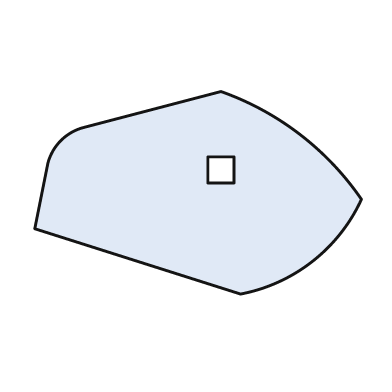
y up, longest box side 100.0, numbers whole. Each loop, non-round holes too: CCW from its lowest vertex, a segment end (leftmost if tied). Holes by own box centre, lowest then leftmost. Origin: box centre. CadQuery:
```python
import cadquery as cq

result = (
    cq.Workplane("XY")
    .moveTo(13.0, -31.0)
    .threePointArc((35.0, -21.0), (50.0, -2.0))
    .threePointArc((31.0, 18.0), (7.0, 31.0))
    .lineTo(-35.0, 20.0)
    .threePointArc((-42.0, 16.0), (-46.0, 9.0))
    .lineTo(-50.0, -11.0)
    .close()
    .moveTo(3.0, 3.0)
    .lineTo(11.0, 3.0)
    .lineTo(11.0, 11.0)
    .lineTo(3.0, 11.0)
    .close()
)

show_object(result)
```